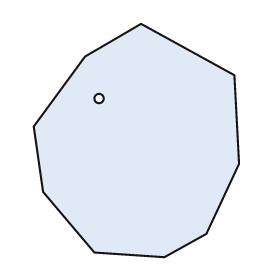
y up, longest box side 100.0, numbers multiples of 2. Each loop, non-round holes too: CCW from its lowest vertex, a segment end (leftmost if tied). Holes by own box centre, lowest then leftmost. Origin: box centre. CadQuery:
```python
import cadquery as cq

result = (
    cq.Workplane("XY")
    .moveTo(12.0, -50.0)
    .lineTo(30.0, -40.0)
    .lineTo(44.0, -10.0)
    .lineTo(42.0, 28.0)
    .lineTo(2.0, 50.0)
    .lineTo(-22.0, 36.0)
    .lineTo(-44.0, 6.0)
    .lineTo(-40.0, -22.0)
    .lineTo(-18.0, -48.0)
    .close()
    .moveTo(-16.0, 18.0)
    .circle(2.0)
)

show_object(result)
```